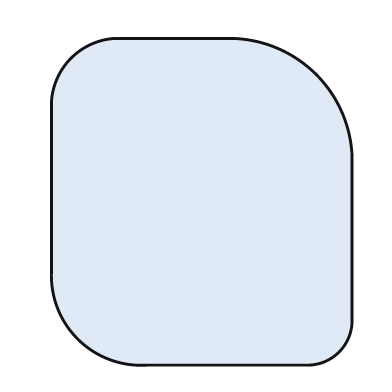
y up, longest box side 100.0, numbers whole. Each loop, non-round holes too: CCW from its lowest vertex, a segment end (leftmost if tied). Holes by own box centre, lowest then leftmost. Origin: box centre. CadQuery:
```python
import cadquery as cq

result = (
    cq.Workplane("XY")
    .moveTo(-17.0, -50.0)
    .lineTo(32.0, -50.0)
    .threePointArc((42.0, -46.0), (46.0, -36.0))
    .lineTo(46.0, 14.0)
    .threePointArc((35.0, 39.0), (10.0, 50.0))
    .lineTo(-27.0, 50.0)
    .threePointArc((-40.0, 44.0), (-46.0, 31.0))
    .lineTo(-46.0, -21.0)
    .threePointArc((-38.0, -42.0), (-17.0, -50.0))
    .close()
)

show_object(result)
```